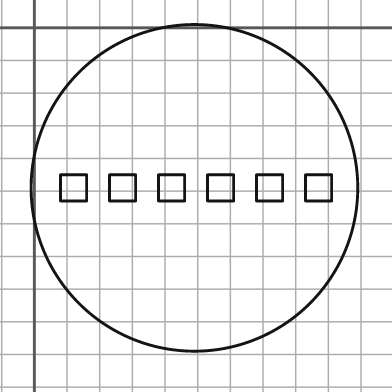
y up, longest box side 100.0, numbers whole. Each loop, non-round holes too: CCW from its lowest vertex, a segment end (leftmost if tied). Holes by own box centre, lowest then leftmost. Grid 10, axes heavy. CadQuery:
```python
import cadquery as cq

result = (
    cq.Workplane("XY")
    .moveTo(49.0, -49.0)
    .circle(50.0)
    .moveTo(8.0, -53.0)
    .lineTo(16.0, -53.0)
    .lineTo(16.0, -45.0)
    .lineTo(8.0, -45.0)
    .close()
    .moveTo(23.0, -53.0)
    .lineTo(31.0, -53.0)
    .lineTo(31.0, -45.0)
    .lineTo(23.0, -45.0)
    .close()
    .moveTo(38.0, -53.0)
    .lineTo(46.0, -53.0)
    .lineTo(46.0, -45.0)
    .lineTo(38.0, -45.0)
    .close()
    .moveTo(53.0, -53.0)
    .lineTo(61.0, -53.0)
    .lineTo(61.0, -45.0)
    .lineTo(53.0, -45.0)
    .close()
    .moveTo(68.0, -53.0)
    .lineTo(76.0, -53.0)
    .lineTo(76.0, -45.0)
    .lineTo(68.0, -45.0)
    .close()
    .moveTo(83.0, -53.0)
    .lineTo(91.0, -53.0)
    .lineTo(91.0, -45.0)
    .lineTo(83.0, -45.0)
    .close()
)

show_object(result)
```